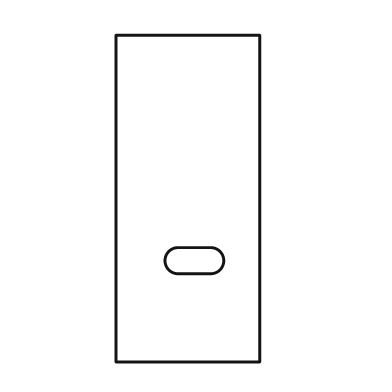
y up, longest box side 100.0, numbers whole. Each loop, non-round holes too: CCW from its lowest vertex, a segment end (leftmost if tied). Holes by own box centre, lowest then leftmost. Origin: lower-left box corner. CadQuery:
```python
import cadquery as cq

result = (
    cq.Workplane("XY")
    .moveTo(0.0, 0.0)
    .lineTo(44.0, 0.0)
    .lineTo(44.0, 100.0)
    .lineTo(0.0, 100.0)
    .close()
    .moveTo(19.0, 27.0)
    .lineTo(29.0, 27.0)
    .threePointArc((33.0, 31.0), (29.0, 35.0))
    .lineTo(19.0, 35.0)
    .threePointArc((15.0, 31.0), (19.0, 27.0))
    .close()
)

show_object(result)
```